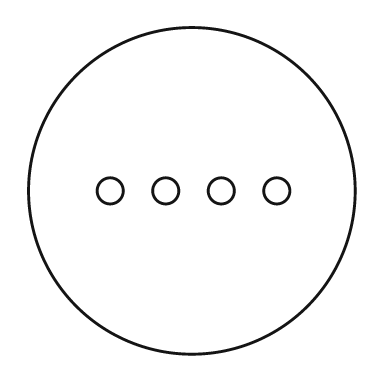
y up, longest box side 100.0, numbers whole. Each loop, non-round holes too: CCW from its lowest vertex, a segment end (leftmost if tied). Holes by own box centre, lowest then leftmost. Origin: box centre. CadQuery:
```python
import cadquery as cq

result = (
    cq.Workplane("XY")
    .moveTo(0.0, 0.0)
    .circle(50.0)
    .moveTo(-25.0, 0.0)
    .circle(4.0)
    .moveTo(-8.0, 0.0)
    .circle(4.0)
    .moveTo(9.0, 0.0)
    .circle(4.0)
    .moveTo(26.0, 0.0)
    .circle(4.0)
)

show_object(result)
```